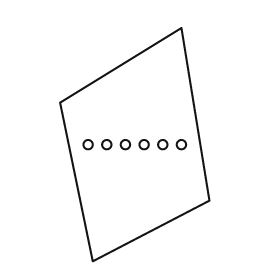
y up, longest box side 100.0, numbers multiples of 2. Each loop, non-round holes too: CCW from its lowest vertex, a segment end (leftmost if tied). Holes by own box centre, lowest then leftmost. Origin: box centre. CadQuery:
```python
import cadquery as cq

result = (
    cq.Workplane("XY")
    .moveTo(-18.0, -50.0)
    .lineTo(32.0, -24.0)
    .lineTo(20.0, 50.0)
    .lineTo(-32.0, 18.0)
    .close()
    .moveTo(-20.0, 0.0)
    .circle(2.0)
    .moveTo(-12.0, 0.0)
    .circle(2.0)
    .moveTo(-4.0, 0.0)
    .circle(2.0)
    .moveTo(4.0, 0.0)
    .circle(2.0)
    .moveTo(12.0, 0.0)
    .circle(2.0)
    .moveTo(20.0, 0.0)
    .circle(2.0)
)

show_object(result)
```